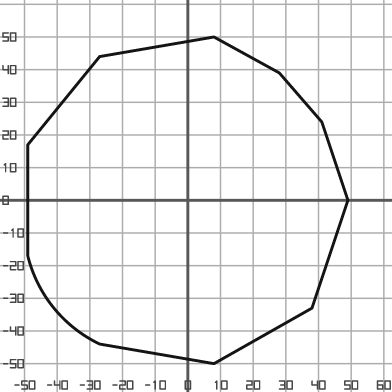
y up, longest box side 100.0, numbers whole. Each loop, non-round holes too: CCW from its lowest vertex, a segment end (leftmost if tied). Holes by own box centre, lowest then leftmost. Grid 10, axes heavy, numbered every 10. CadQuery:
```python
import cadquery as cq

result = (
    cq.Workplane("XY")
    .moveTo(8.0, -50.0)
    .lineTo(38.0, -33.0)
    .lineTo(49.0, 0.0)
    .lineTo(41.0, 24.0)
    .lineTo(28.0, 39.0)
    .lineTo(8.0, 50.0)
    .lineTo(-27.0, 44.0)
    .lineTo(-49.0, 17.0)
    .lineTo(-49.0, -17.0)
    .threePointArc((-41.0, -33.0), (-27.0, -44.0))
    .close()
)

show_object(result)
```